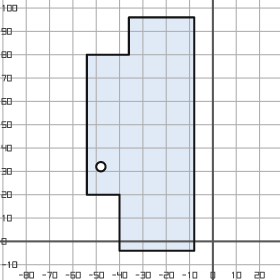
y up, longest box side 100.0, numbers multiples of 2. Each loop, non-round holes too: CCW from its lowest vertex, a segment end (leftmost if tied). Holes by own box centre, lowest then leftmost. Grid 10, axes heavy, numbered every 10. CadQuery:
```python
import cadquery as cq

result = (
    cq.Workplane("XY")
    .moveTo(-40.0, -4.0)
    .lineTo(-8.0, -4.0)
    .lineTo(-8.0, 96.0)
    .lineTo(-36.0, 96.0)
    .lineTo(-36.0, 80.0)
    .lineTo(-54.0, 80.0)
    .lineTo(-54.0, 20.0)
    .lineTo(-40.0, 20.0)
    .close()
    .moveTo(-48.0, 32.0)
    .circle(2.0)
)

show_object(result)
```